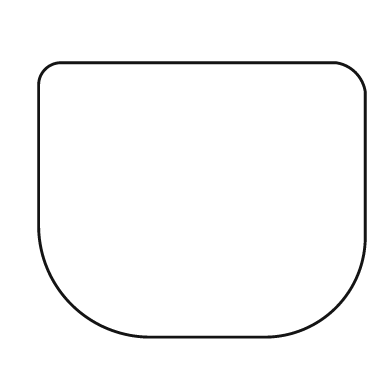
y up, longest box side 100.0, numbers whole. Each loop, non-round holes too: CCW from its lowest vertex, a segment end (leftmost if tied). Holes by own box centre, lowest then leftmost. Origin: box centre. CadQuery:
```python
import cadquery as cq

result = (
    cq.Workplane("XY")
    .moveTo(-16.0, -42.0)
    .lineTo(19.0, -42.0)
    .threePointArc((41.0, -33.0), (50.0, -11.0))
    .lineTo(50.0, 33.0)
    .threePointArc((47.0, 39.0), (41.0, 42.0))
    .lineTo(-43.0, 42.0)
    .threePointArc((-48.0, 40.0), (-50.0, 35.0))
    .lineTo(-50.0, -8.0)
    .threePointArc((-40.0, -32.0), (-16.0, -42.0))
    .close()
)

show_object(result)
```